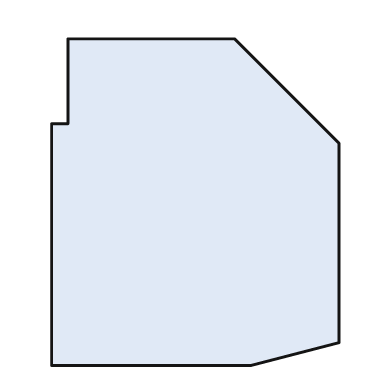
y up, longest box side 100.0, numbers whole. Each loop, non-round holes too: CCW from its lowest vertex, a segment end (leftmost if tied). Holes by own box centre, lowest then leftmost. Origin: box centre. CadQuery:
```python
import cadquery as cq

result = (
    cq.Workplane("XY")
    .moveTo(-44.0, -50.0)
    .lineTo(17.0, -50.0)
    .lineTo(44.0, -43.0)
    .lineTo(44.0, 18.0)
    .lineTo(12.0, 50.0)
    .lineTo(-39.0, 50.0)
    .lineTo(-39.0, 24.0)
    .lineTo(-44.0, 24.0)
    .close()
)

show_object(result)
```